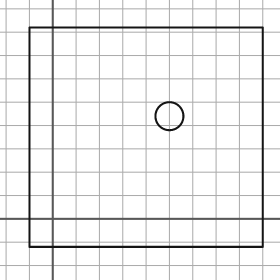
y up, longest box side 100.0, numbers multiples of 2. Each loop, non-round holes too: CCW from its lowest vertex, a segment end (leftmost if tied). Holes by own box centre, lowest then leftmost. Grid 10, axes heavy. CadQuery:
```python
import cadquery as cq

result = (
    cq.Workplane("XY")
    .moveTo(-10.0, -12.0)
    .lineTo(90.0, -12.0)
    .lineTo(90.0, 82.0)
    .lineTo(-10.0, 82.0)
    .close()
    .moveTo(50.0, 44.0)
    .circle(6.0)
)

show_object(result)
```